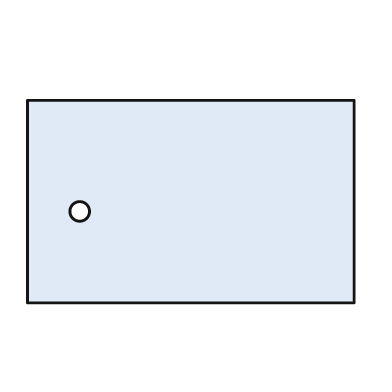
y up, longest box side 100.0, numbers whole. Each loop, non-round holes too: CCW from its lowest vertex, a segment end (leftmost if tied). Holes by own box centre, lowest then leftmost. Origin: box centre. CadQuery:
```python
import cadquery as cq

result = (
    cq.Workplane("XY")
    .moveTo(-50.0, -31.0)
    .lineTo(50.0, -31.0)
    .lineTo(50.0, 31.0)
    .lineTo(-50.0, 31.0)
    .close()
    .moveTo(-34.0, -3.0)
    .circle(3.0)
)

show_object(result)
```